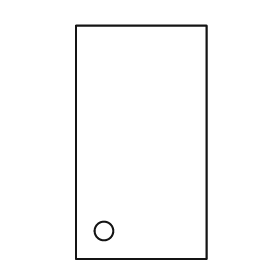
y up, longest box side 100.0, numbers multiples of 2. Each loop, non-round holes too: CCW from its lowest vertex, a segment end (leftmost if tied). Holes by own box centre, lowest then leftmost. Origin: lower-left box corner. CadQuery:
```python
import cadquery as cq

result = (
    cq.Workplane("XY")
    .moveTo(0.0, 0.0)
    .lineTo(56.0, 0.0)
    .lineTo(56.0, 100.0)
    .lineTo(0.0, 100.0)
    .close()
    .moveTo(12.0, 12.0)
    .circle(4.0)
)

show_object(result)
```